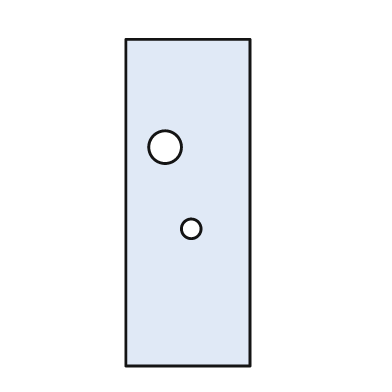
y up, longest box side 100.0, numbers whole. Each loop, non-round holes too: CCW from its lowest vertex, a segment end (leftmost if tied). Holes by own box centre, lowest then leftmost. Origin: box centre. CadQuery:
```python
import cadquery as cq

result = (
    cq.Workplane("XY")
    .moveTo(-19.0, -50.0)
    .lineTo(19.0, -50.0)
    .lineTo(19.0, 50.0)
    .lineTo(-19.0, 50.0)
    .close()
    .moveTo(1.0, -8.0)
    .circle(3.0)
    .moveTo(-7.0, 17.0)
    .circle(5.0)
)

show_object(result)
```